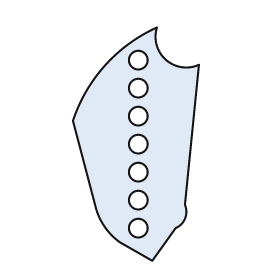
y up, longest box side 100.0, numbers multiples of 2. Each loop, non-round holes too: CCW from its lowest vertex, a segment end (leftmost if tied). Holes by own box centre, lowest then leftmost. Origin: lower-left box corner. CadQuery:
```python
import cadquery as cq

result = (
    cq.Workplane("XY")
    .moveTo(34.0, 0.0)
    .lineTo(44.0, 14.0)
    .threePointArc((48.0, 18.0), (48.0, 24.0))
    .lineTo(54.0, 84.0)
    .threePointArc((40.0, 86.0), (36.0, 100.0))
    .threePointArc((14.0, 84.0), (0.0, 60.0))
    .lineTo(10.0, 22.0)
    .threePointArc((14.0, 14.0), (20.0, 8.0))
    .close()
    .moveTo(28.0, 14.0)
    .circle(4.0)
    .moveTo(28.0, 26.0)
    .circle(4.0)
    .moveTo(28.0, 38.0)
    .circle(4.0)
    .moveTo(28.0, 50.0)
    .circle(4.0)
    .moveTo(28.0, 62.0)
    .circle(4.0)
    .moveTo(28.0, 74.0)
    .circle(4.0)
    .moveTo(28.0, 86.0)
    .circle(4.0)
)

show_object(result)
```